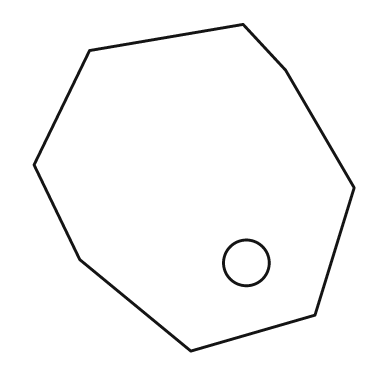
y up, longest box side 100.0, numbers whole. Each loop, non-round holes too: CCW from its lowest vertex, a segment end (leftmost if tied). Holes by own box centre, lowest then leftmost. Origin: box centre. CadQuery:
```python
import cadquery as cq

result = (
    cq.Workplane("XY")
    .moveTo(-1.0, -50.0)
    .lineTo(37.0, -39.0)
    .lineTo(49.0, 0.0)
    .lineTo(28.0, 36.0)
    .lineTo(15.0, 50.0)
    .lineTo(-32.0, 42.0)
    .lineTo(-49.0, 7.0)
    .lineTo(-35.0, -22.0)
    .close()
    .moveTo(16.0, -23.0)
    .circle(7.0)
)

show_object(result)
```